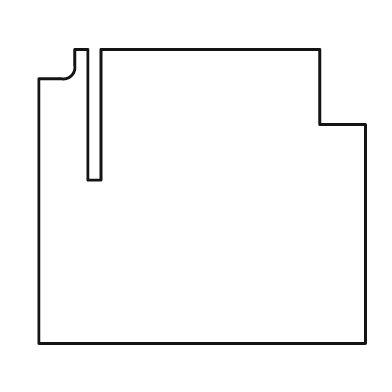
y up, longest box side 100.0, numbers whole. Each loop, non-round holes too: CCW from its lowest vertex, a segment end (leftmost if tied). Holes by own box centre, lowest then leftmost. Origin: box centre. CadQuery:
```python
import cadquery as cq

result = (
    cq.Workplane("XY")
    .moveTo(-50.0, -45.0)
    .lineTo(50.0, -45.0)
    .lineTo(50.0, 22.0)
    .lineTo(36.0, 22.0)
    .lineTo(36.0, 45.0)
    .lineTo(-31.0, 45.0)
    .lineTo(-31.0, 5.0)
    .lineTo(-35.0, 5.0)
    .lineTo(-35.0, 45.0)
    .lineTo(-39.0, 45.0)
    .lineTo(-39.0, 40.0)
    .threePointArc((-40.0, 37.0), (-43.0, 36.0))
    .lineTo(-50.0, 36.0)
    .close()
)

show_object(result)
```